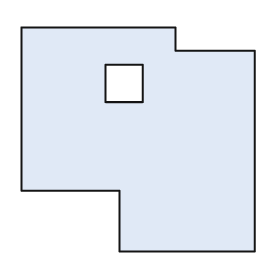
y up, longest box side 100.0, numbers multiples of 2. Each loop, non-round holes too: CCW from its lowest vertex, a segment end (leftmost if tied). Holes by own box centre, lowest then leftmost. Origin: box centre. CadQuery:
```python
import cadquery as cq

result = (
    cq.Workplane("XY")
    .moveTo(-8.0, -48.0)
    .lineTo(50.0, -48.0)
    .lineTo(50.0, 38.0)
    .lineTo(16.0, 38.0)
    .lineTo(16.0, 48.0)
    .lineTo(-50.0, 48.0)
    .lineTo(-50.0, -22.0)
    .lineTo(-8.0, -22.0)
    .close()
    .moveTo(-14.0, 16.0)
    .lineTo(2.0, 16.0)
    .lineTo(2.0, 32.0)
    .lineTo(-14.0, 32.0)
    .close()
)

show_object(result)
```